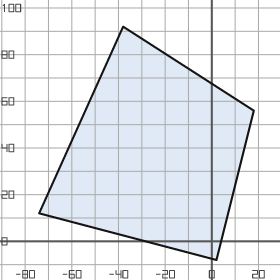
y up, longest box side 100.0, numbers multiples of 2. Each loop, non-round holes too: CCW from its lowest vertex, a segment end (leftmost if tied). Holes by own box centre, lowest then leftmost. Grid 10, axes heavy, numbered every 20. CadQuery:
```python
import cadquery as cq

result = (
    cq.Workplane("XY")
    .moveTo(2.0, -8.0)
    .lineTo(18.0, 56.0)
    .lineTo(-38.0, 92.0)
    .lineTo(-74.0, 12.0)
    .close()
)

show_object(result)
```